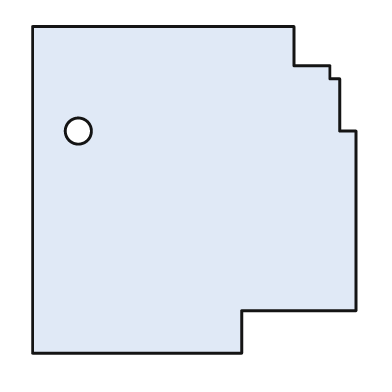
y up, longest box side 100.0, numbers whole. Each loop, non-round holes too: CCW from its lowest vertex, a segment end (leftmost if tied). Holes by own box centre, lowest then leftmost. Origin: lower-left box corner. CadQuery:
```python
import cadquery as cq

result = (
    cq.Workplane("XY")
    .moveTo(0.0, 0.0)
    .lineTo(64.0, 0.0)
    .lineTo(64.0, 13.0)
    .lineTo(99.0, 13.0)
    .lineTo(99.0, 68.0)
    .lineTo(94.0, 68.0)
    .lineTo(94.0, 84.0)
    .lineTo(91.0, 84.0)
    .lineTo(91.0, 88.0)
    .lineTo(80.0, 88.0)
    .lineTo(80.0, 100.0)
    .lineTo(0.0, 100.0)
    .close()
    .moveTo(14.0, 68.0)
    .circle(4.0)
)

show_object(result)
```